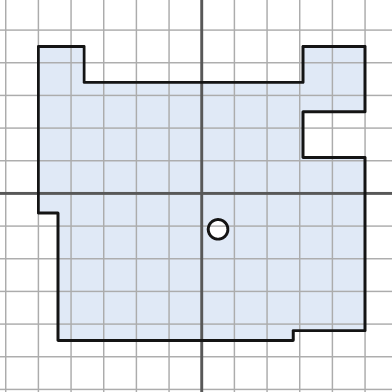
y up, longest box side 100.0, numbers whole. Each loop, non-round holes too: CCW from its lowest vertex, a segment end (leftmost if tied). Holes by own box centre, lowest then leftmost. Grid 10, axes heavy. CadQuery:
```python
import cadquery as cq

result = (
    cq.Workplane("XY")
    .moveTo(-44.0, -45.0)
    .lineTo(28.0, -45.0)
    .lineTo(28.0, -42.0)
    .lineTo(50.0, -42.0)
    .lineTo(50.0, 11.0)
    .lineTo(31.0, 11.0)
    .lineTo(31.0, 25.0)
    .lineTo(50.0, 25.0)
    .lineTo(50.0, 45.0)
    .lineTo(31.0, 45.0)
    .lineTo(31.0, 34.0)
    .lineTo(-36.0, 34.0)
    .lineTo(-36.0, 45.0)
    .lineTo(-50.0, 45.0)
    .lineTo(-50.0, -6.0)
    .lineTo(-44.0, -6.0)
    .close()
    .moveTo(5.0, -11.0)
    .circle(3.0)
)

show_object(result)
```